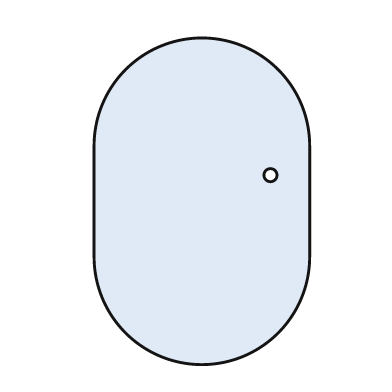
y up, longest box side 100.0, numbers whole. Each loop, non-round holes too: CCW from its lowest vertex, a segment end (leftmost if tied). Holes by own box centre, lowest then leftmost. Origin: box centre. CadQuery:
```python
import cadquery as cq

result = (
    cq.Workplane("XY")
    .moveTo(-33.0, -17.0)
    .threePointArc((0.0, -50.0), (33.0, -17.0))
    .lineTo(33.0, 17.0)
    .threePointArc((0.0, 50.0), (-33.0, 17.0))
    .close()
    .moveTo(21.0, 8.0)
    .circle(2.0)
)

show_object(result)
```